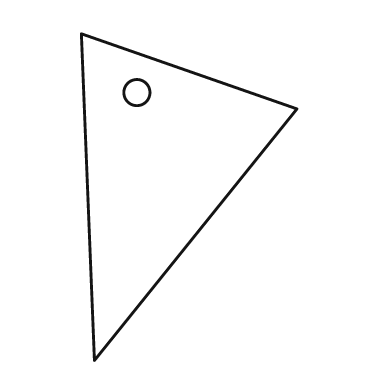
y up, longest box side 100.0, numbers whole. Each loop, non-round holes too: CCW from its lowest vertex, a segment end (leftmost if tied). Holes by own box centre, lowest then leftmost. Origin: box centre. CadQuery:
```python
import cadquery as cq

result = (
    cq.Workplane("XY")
    .moveTo(-29.0, -50.0)
    .lineTo(33.0, 27.0)
    .lineTo(-33.0, 50.0)
    .close()
    .moveTo(-16.0, 32.0)
    .circle(4.0)
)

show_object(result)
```